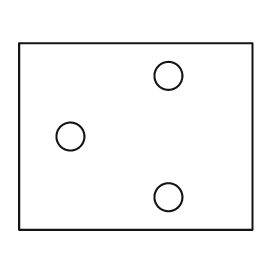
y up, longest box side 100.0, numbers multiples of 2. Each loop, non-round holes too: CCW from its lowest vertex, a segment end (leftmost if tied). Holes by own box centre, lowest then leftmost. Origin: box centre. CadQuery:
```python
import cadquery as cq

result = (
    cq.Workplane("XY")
    .moveTo(-50.0, -40.0)
    .lineTo(50.0, -40.0)
    .lineTo(50.0, 40.0)
    .lineTo(-50.0, 40.0)
    .close()
    .moveTo(14.0, -26.0)
    .circle(6.0)
    .moveTo(-28.0, 0.0)
    .circle(6.0)
    .moveTo(14.0, 26.0)
    .circle(6.0)
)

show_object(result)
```